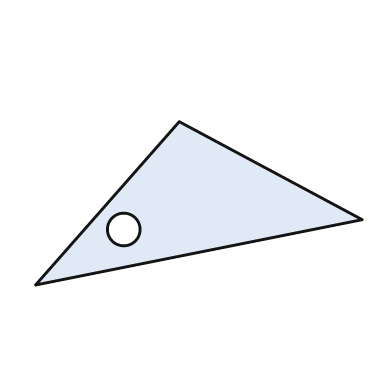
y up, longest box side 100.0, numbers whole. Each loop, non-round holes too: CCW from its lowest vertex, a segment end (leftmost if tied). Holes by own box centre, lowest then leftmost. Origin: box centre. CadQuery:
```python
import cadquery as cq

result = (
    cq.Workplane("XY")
    .moveTo(-50.0, -25.0)
    .lineTo(50.0, -5.0)
    .lineTo(-6.0, 25.0)
    .close()
    .moveTo(-23.0, -8.0)
    .circle(5.0)
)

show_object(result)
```